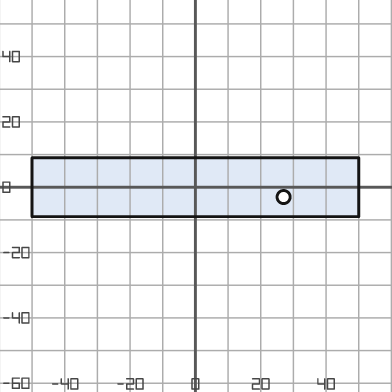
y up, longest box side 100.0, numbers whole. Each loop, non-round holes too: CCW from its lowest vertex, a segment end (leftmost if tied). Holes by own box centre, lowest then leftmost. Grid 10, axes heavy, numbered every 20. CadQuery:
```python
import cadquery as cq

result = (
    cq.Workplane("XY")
    .moveTo(-50.0, -9.0)
    .lineTo(50.0, -9.0)
    .lineTo(50.0, 9.0)
    .lineTo(-50.0, 9.0)
    .close()
    .moveTo(27.0, -3.0)
    .circle(2.0)
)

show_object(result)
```